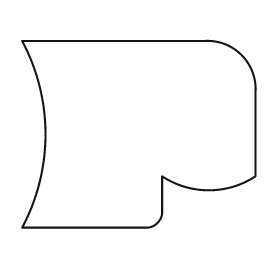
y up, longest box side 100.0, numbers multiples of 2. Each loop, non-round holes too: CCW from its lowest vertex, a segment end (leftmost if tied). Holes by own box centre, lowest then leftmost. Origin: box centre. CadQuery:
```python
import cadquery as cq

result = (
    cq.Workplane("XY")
    .moveTo(-50.0, -40.0)
    .lineTo(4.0, -40.0)
    .threePointArc((8.0, -38.0), (10.0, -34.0))
    .lineTo(10.0, -18.0)
    .threePointArc((30.0, -24.0), (50.0, -18.0))
    .lineTo(50.0, 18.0)
    .threePointArc((44.0, 34.0), (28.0, 40.0))
    .lineTo(-50.0, 40.0)
    .threePointArc((-40.0, 0.0), (-50.0, -40.0))
    .close()
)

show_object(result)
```